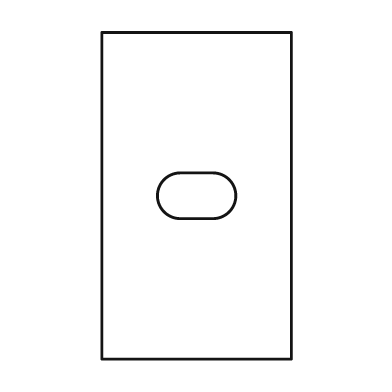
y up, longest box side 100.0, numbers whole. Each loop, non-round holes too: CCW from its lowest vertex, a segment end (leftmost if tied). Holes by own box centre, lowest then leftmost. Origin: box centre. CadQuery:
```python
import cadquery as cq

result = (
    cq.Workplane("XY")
    .moveTo(-29.0, -50.0)
    .lineTo(29.0, -50.0)
    .lineTo(29.0, 50.0)
    .lineTo(-29.0, 50.0)
    .close()
    .moveTo(-5.0, -7.0)
    .lineTo(5.0, -7.0)
    .threePointArc((12.0, 0.0), (5.0, 7.0))
    .lineTo(-5.0, 7.0)
    .threePointArc((-12.0, 0.0), (-5.0, -7.0))
    .close()
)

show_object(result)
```